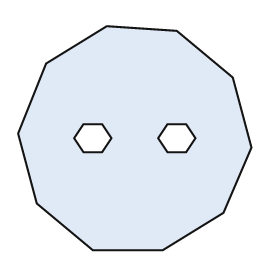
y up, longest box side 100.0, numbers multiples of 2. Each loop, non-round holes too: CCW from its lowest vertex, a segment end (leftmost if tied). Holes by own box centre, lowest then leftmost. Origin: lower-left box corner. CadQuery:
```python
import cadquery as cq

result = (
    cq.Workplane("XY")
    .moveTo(32.0, 0.0)
    .lineTo(62.0, 0.0)
    .lineTo(88.0, 16.0)
    .lineTo(100.0, 44.0)
    .lineTo(92.0, 74.0)
    .lineTo(68.0, 94.0)
    .lineTo(38.0, 96.0)
    .lineTo(12.0, 80.0)
    .lineTo(0.0, 50.0)
    .lineTo(8.0, 20.0)
    .close()
    .moveTo(28.0, 42.0)
    .lineTo(36.0, 42.0)
    .lineTo(40.0, 48.0)
    .lineTo(36.0, 54.0)
    .lineTo(28.0, 54.0)
    .lineTo(24.0, 48.0)
    .close()
    .moveTo(64.0, 42.0)
    .lineTo(72.0, 42.0)
    .lineTo(76.0, 48.0)
    .lineTo(72.0, 54.0)
    .lineTo(64.0, 54.0)
    .lineTo(60.0, 48.0)
    .close()
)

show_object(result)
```